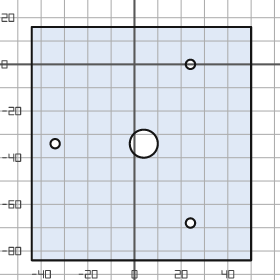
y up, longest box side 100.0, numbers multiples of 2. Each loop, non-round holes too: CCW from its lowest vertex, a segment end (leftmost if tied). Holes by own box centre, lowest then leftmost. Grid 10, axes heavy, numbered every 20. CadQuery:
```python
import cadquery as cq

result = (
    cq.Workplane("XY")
    .moveTo(-44.0, -84.0)
    .lineTo(50.0, -84.0)
    .lineTo(50.0, 16.0)
    .lineTo(-44.0, 16.0)
    .close()
    .moveTo(24.0, -68.0)
    .circle(2.0)
    .moveTo(-34.0, -34.0)
    .circle(2.0)
    .moveTo(4.0, -34.0)
    .circle(6.0)
    .moveTo(24.0, 0.0)
    .circle(2.0)
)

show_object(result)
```